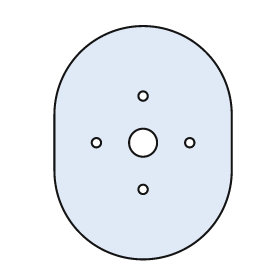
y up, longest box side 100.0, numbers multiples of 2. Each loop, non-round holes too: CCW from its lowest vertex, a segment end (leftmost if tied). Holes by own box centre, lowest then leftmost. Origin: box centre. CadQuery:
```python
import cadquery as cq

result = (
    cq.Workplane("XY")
    .moveTo(-38.0, -12.0)
    .threePointArc((0.0, -50.0), (38.0, -12.0))
    .lineTo(38.0, 12.0)
    .threePointArc((0.0, 50.0), (-38.0, 12.0))
    .close()
    .moveTo(0.0, -20.0)
    .circle(2.0)
    .moveTo(-20.0, 0.0)
    .circle(2.0)
    .moveTo(0.0, 0.0)
    .circle(6.0)
    .moveTo(20.0, 0.0)
    .circle(2.0)
    .moveTo(0.0, 20.0)
    .circle(2.0)
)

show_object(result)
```